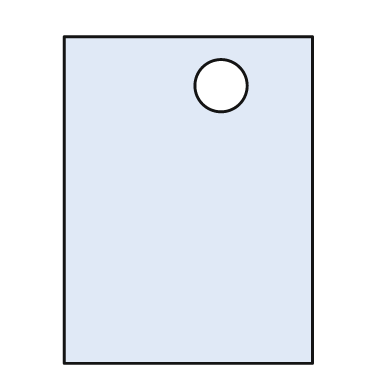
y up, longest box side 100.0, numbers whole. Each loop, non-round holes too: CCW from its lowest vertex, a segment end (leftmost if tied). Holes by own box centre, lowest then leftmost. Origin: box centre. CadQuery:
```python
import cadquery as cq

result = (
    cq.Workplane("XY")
    .moveTo(-38.0, -50.0)
    .lineTo(38.0, -50.0)
    .lineTo(38.0, 50.0)
    .lineTo(-38.0, 50.0)
    .close()
    .moveTo(10.0, 35.0)
    .circle(8.0)
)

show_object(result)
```